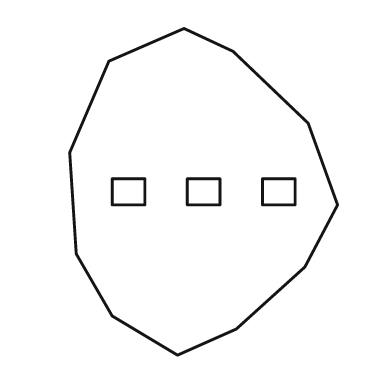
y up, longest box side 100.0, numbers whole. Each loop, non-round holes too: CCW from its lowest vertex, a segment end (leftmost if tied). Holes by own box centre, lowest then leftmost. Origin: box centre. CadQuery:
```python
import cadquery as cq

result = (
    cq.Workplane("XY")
    .moveTo(-8.0, -50.0)
    .lineTo(10.0, -42.0)
    .lineTo(31.0, -23.0)
    .lineTo(41.0, -4.0)
    .lineTo(32.0, 21.0)
    .lineTo(9.0, 43.0)
    .lineTo(-6.0, 50.0)
    .lineTo(-29.0, 40.0)
    .lineTo(-41.0, 12.0)
    .lineTo(-39.0, -19.0)
    .lineTo(-28.0, -38.0)
    .close()
    .moveTo(-28.0, -4.0)
    .lineTo(-18.0, -4.0)
    .lineTo(-18.0, 4.0)
    .lineTo(-28.0, 4.0)
    .close()
    .moveTo(-5.0, -4.0)
    .lineTo(5.0, -4.0)
    .lineTo(5.0, 4.0)
    .lineTo(-5.0, 4.0)
    .close()
    .moveTo(18.0, -4.0)
    .lineTo(28.0, -4.0)
    .lineTo(28.0, 4.0)
    .lineTo(18.0, 4.0)
    .close()
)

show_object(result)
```